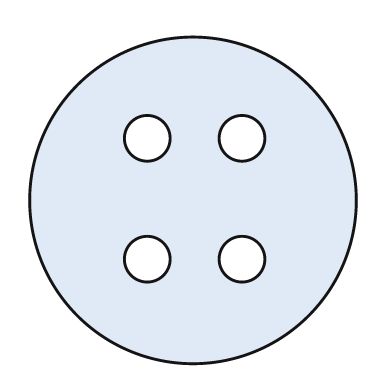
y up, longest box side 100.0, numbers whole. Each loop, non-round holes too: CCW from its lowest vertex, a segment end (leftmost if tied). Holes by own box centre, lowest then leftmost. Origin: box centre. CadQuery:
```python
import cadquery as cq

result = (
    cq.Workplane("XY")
    .moveTo(0.0, 0.0)
    .circle(50.0)
    .moveTo(-14.0, -18.0)
    .circle(7.0)
    .moveTo(15.0, -18.0)
    .circle(7.0)
    .moveTo(-14.0, 19.0)
    .circle(7.0)
    .moveTo(15.0, 19.0)
    .circle(7.0)
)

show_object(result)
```